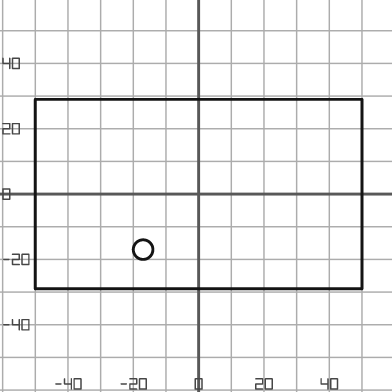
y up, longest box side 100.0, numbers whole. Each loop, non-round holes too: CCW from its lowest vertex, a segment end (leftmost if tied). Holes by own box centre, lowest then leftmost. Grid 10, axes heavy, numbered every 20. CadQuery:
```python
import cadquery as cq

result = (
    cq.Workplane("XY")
    .moveTo(-50.0, -29.0)
    .lineTo(50.0, -29.0)
    .lineTo(50.0, 29.0)
    .lineTo(-50.0, 29.0)
    .close()
    .moveTo(-17.0, -17.0)
    .circle(3.0)
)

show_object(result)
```